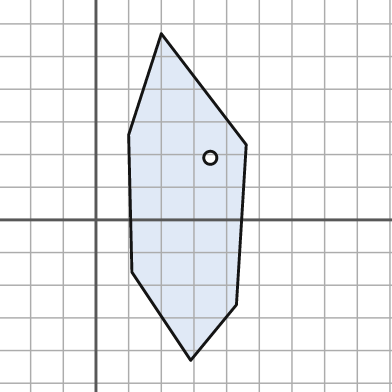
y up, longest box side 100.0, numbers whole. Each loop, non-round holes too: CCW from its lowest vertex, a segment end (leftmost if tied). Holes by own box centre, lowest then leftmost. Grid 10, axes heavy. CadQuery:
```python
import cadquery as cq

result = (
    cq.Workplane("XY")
    .moveTo(29.0, -43.0)
    .lineTo(43.0, -26.0)
    .lineTo(46.0, 23.0)
    .lineTo(20.0, 57.0)
    .lineTo(10.0, 26.0)
    .lineTo(11.0, -16.0)
    .close()
    .moveTo(35.0, 19.0)
    .circle(2.0)
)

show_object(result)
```